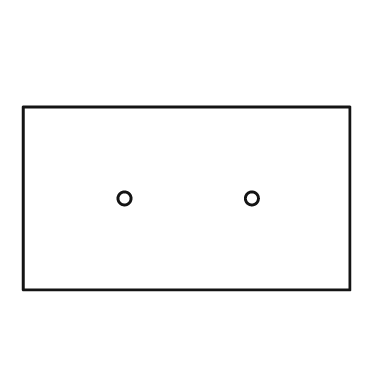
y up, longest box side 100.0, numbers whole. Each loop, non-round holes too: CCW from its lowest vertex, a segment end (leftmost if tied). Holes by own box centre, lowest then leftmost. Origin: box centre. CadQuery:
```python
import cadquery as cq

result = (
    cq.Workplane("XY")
    .moveTo(-50.0, -28.0)
    .lineTo(50.0, -28.0)
    .lineTo(50.0, 28.0)
    .lineTo(-50.0, 28.0)
    .close()
    .moveTo(-19.0, 0.0)
    .circle(2.0)
    .moveTo(20.0, 0.0)
    .circle(2.0)
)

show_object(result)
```